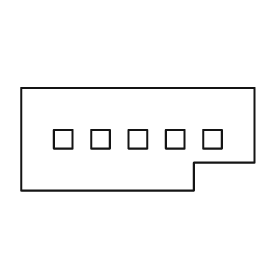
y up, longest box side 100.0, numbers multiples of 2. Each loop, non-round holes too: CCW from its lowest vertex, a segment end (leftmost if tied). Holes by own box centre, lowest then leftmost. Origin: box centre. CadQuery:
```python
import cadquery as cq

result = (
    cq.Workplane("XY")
    .moveTo(-50.0, -22.0)
    .lineTo(24.0, -22.0)
    .lineTo(24.0, -10.0)
    .lineTo(50.0, -10.0)
    .lineTo(50.0, 22.0)
    .lineTo(-50.0, 22.0)
    .close()
    .moveTo(-36.0, -4.0)
    .lineTo(-28.0, -4.0)
    .lineTo(-28.0, 4.0)
    .lineTo(-36.0, 4.0)
    .close()
    .moveTo(-20.0, -4.0)
    .lineTo(-12.0, -4.0)
    .lineTo(-12.0, 4.0)
    .lineTo(-20.0, 4.0)
    .close()
    .moveTo(-4.0, -4.0)
    .lineTo(4.0, -4.0)
    .lineTo(4.0, 4.0)
    .lineTo(-4.0, 4.0)
    .close()
    .moveTo(12.0, -4.0)
    .lineTo(20.0, -4.0)
    .lineTo(20.0, 4.0)
    .lineTo(12.0, 4.0)
    .close()
    .moveTo(28.0, -4.0)
    .lineTo(36.0, -4.0)
    .lineTo(36.0, 4.0)
    .lineTo(28.0, 4.0)
    .close()
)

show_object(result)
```